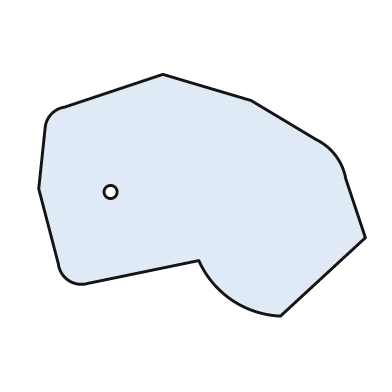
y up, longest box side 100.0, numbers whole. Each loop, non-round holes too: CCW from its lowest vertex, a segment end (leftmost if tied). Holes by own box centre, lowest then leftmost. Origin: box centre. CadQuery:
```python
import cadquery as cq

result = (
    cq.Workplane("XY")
    .moveTo(24.0, -37.0)
    .lineTo(50.0, -13.0)
    .lineTo(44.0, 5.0)
    .threePointArc((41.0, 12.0), (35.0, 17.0))
    .lineTo(15.0, 29.0)
    .lineTo(-12.0, 37.0)
    .lineTo(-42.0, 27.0)
    .threePointArc((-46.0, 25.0), (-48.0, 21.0))
    .lineTo(-50.0, 2.0)
    .lineTo(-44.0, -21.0)
    .threePointArc((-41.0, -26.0), (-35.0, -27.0))
    .lineTo(-1.0, -20.0)
    .threePointArc((9.0, -32.0), (24.0, -37.0))
    .close()
    .moveTo(-28.0, 1.0)
    .circle(2.0)
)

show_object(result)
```